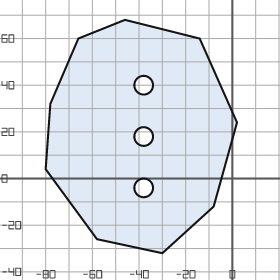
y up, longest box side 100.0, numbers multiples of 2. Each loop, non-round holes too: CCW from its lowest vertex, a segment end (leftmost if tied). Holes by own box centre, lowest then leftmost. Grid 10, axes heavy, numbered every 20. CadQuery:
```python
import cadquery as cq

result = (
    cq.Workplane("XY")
    .moveTo(-30.0, -32.0)
    .lineTo(-8.0, -12.0)
    .lineTo(2.0, 24.0)
    .lineTo(-14.0, 60.0)
    .lineTo(-46.0, 68.0)
    .lineTo(-66.0, 60.0)
    .lineTo(-78.0, 32.0)
    .lineTo(-80.0, 4.0)
    .lineTo(-58.0, -26.0)
    .close()
    .moveTo(-38.0, -4.0)
    .circle(4.0)
    .moveTo(-38.0, 18.0)
    .circle(4.0)
    .moveTo(-38.0, 40.0)
    .circle(4.0)
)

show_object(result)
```